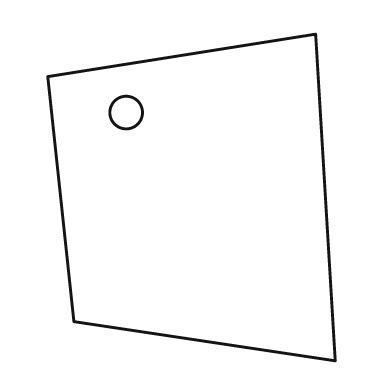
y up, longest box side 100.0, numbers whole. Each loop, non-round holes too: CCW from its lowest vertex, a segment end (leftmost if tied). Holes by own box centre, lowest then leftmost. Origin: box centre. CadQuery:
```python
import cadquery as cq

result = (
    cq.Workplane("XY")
    .moveTo(44.0, -50.0)
    .lineTo(38.0, 50.0)
    .lineTo(-44.0, 37.0)
    .lineTo(-36.0, -38.0)
    .close()
    .moveTo(-20.0, 26.0)
    .circle(5.0)
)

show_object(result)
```